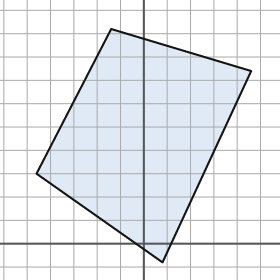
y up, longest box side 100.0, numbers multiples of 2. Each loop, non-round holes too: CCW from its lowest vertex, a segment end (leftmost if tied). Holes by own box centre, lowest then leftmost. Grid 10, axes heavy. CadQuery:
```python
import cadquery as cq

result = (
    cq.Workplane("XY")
    .moveTo(8.0, -8.0)
    .lineTo(46.0, 74.0)
    .lineTo(-14.0, 92.0)
    .lineTo(-46.0, 30.0)
    .close()
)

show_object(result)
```